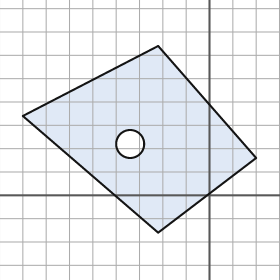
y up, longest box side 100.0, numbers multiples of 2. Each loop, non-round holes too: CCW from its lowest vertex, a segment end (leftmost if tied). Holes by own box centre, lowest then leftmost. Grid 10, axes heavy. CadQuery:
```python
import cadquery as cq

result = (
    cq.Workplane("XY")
    .moveTo(-22.0, -16.0)
    .lineTo(20.0, 16.0)
    .lineTo(-22.0, 64.0)
    .lineTo(-80.0, 34.0)
    .close()
    .moveTo(-34.0, 22.0)
    .circle(6.0)
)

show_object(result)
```